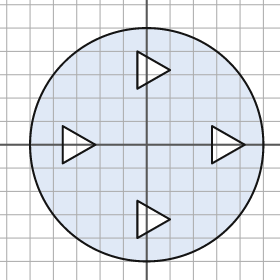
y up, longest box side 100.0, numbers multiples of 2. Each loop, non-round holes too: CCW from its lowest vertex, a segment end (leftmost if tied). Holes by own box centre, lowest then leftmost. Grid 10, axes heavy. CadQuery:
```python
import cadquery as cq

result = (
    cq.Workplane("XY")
    .moveTo(0.0, 0.0)
    .circle(50.0)
    .moveTo(-4.0, -40.0)
    .lineTo(10.0, -32.0)
    .lineTo(-4.0, -24.0)
    .close()
    .moveTo(-36.0, -8.0)
    .lineTo(-22.0, 0.0)
    .lineTo(-36.0, 8.0)
    .close()
    .moveTo(28.0, -8.0)
    .lineTo(42.0, 0.0)
    .lineTo(28.0, 8.0)
    .close()
    .moveTo(-4.0, 24.0)
    .lineTo(10.0, 32.0)
    .lineTo(-4.0, 40.0)
    .close()
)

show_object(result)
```